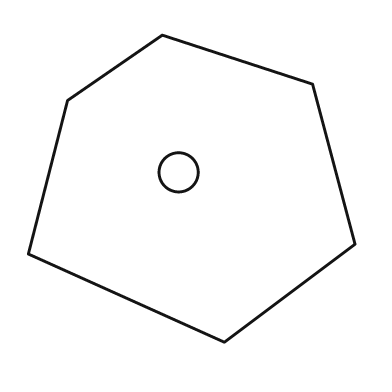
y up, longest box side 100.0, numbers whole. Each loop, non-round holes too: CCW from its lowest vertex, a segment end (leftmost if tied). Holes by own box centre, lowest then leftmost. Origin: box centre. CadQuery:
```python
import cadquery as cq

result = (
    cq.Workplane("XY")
    .moveTo(10.0, -47.0)
    .lineTo(50.0, -17.0)
    .lineTo(37.0, 32.0)
    .lineTo(-9.0, 47.0)
    .lineTo(-38.0, 27.0)
    .lineTo(-50.0, -20.0)
    .close()
    .moveTo(-4.0, 5.0)
    .circle(6.0)
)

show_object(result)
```